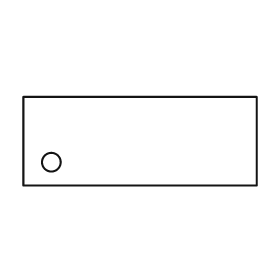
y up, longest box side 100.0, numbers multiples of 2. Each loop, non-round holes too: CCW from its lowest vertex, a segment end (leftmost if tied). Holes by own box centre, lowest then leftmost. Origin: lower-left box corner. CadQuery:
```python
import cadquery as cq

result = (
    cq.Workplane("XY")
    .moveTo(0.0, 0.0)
    .lineTo(100.0, 0.0)
    .lineTo(100.0, 38.0)
    .lineTo(0.0, 38.0)
    .close()
    .moveTo(12.0, 10.0)
    .circle(4.0)
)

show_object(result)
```